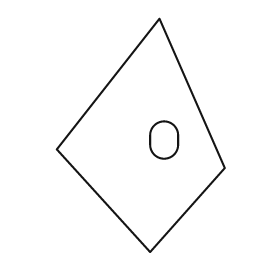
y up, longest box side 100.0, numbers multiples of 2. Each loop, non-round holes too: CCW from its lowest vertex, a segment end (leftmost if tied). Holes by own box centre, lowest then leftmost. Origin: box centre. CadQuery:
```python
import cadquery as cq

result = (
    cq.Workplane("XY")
    .moveTo(4.0, -50.0)
    .lineTo(36.0, -14.0)
    .lineTo(8.0, 50.0)
    .lineTo(-36.0, -6.0)
    .close()
    .moveTo(4.0, -4.0)
    .threePointArc((10.0, -10.0), (16.0, -4.0))
    .lineTo(16.0, 0.0)
    .threePointArc((10.0, 6.0), (4.0, 0.0))
    .close()
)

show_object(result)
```